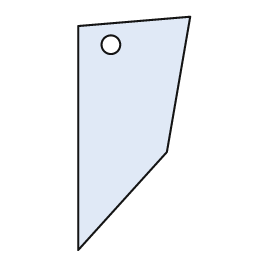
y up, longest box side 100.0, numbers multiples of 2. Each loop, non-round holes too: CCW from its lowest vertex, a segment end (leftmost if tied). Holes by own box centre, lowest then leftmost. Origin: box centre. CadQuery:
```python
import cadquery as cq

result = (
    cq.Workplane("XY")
    .moveTo(-24.0, -50.0)
    .lineTo(14.0, -8.0)
    .lineTo(24.0, 50.0)
    .lineTo(-24.0, 46.0)
    .close()
    .moveTo(-10.0, 38.0)
    .circle(4.0)
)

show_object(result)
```